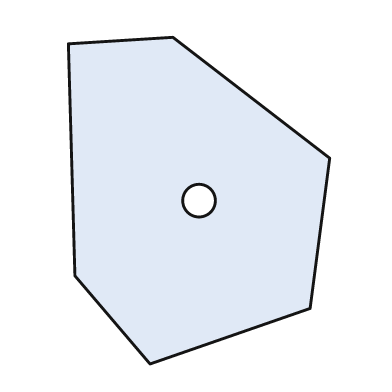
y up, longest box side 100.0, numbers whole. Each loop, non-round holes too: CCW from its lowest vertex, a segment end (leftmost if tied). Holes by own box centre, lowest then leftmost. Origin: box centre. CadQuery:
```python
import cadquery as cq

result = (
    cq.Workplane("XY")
    .moveTo(-15.0, -50.0)
    .lineTo(34.0, -33.0)
    .lineTo(40.0, 13.0)
    .lineTo(-8.0, 50.0)
    .lineTo(-40.0, 48.0)
    .lineTo(-38.0, -23.0)
    .close()
    .moveTo(0.0, 0.0)
    .circle(5.0)
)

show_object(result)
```